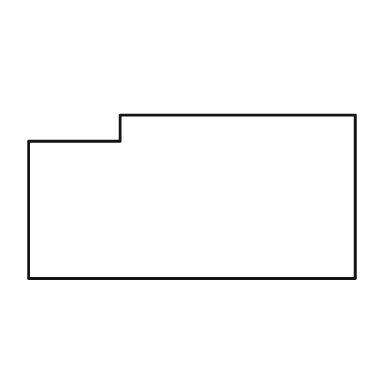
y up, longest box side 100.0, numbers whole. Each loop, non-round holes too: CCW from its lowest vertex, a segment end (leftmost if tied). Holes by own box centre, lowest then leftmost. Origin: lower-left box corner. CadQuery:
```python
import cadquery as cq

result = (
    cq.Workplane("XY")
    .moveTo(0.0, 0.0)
    .lineTo(100.0, 0.0)
    .lineTo(100.0, 50.0)
    .lineTo(28.0, 50.0)
    .lineTo(28.0, 42.0)
    .lineTo(0.0, 42.0)
    .close()
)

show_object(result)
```